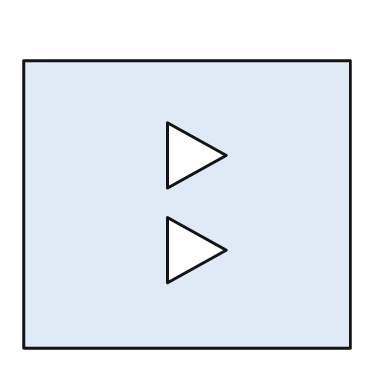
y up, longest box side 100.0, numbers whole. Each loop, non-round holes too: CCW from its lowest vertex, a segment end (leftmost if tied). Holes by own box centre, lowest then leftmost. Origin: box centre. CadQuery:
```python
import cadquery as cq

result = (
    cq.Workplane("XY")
    .moveTo(-50.0, -44.0)
    .lineTo(50.0, -44.0)
    .lineTo(50.0, 44.0)
    .lineTo(-50.0, 44.0)
    .close()
    .moveTo(-6.0, -24.0)
    .lineTo(12.0, -14.0)
    .lineTo(-6.0, -4.0)
    .close()
    .moveTo(-6.0, 5.0)
    .lineTo(12.0, 15.0)
    .lineTo(-6.0, 25.0)
    .close()
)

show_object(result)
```